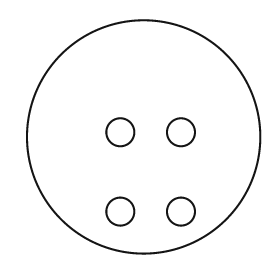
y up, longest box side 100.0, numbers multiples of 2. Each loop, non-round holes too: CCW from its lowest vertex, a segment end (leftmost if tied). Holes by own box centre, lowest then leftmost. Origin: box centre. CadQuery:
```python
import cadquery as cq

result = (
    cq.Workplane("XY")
    .moveTo(0.0, 0.0)
    .circle(50.0)
    .moveTo(-10.0, -32.0)
    .circle(6.0)
    .moveTo(16.0, -32.0)
    .circle(6.0)
    .moveTo(-10.0, 2.0)
    .circle(6.0)
    .moveTo(16.0, 2.0)
    .circle(6.0)
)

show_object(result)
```